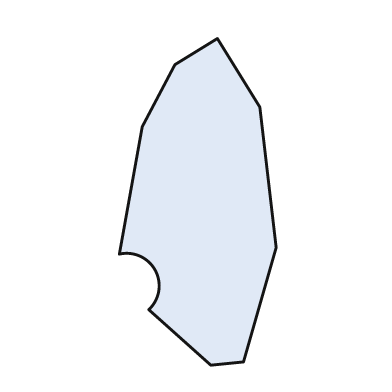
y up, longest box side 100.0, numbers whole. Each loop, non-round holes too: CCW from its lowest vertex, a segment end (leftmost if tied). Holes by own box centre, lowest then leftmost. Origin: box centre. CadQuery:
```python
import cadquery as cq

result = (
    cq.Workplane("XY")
    .moveTo(4.0, -50.0)
    .lineTo(14.0, -49.0)
    .lineTo(24.0, -14.0)
    .lineTo(19.0, 29.0)
    .lineTo(6.0, 50.0)
    .lineTo(-7.0, 42.0)
    .lineTo(-17.0, 23.0)
    .lineTo(-24.0, -16.0)
    .threePointArc((-13.0, -21.0), (-15.0, -33.0))
    .close()
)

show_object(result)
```